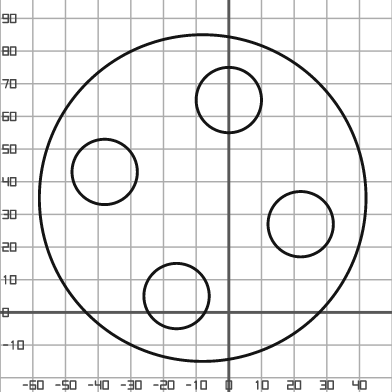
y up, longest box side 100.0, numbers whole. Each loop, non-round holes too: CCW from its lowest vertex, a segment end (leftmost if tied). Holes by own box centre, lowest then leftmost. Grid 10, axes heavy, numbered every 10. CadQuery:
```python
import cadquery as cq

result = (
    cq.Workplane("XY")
    .moveTo(-8.0, 35.0)
    .circle(50.0)
    .moveTo(-16.0, 5.0)
    .circle(10.0)
    .moveTo(22.0, 27.0)
    .circle(10.0)
    .moveTo(-38.0, 43.0)
    .circle(10.0)
    .moveTo(0.0, 65.0)
    .circle(10.0)
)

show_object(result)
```